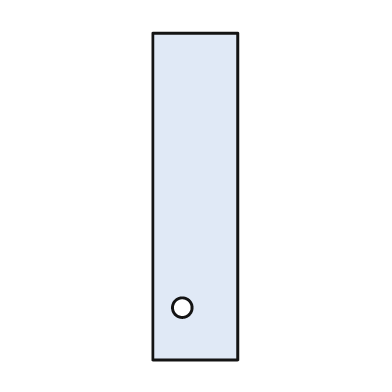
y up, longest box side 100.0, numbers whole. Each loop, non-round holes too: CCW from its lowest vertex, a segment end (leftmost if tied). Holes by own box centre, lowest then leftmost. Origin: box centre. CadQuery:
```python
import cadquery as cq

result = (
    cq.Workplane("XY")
    .moveTo(-13.0, -50.0)
    .lineTo(13.0, -50.0)
    .lineTo(13.0, 50.0)
    .lineTo(-13.0, 50.0)
    .close()
    .moveTo(-4.0, -34.0)
    .circle(3.0)
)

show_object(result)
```